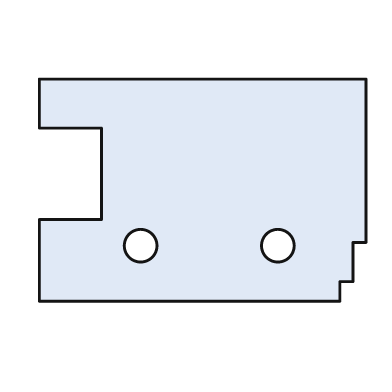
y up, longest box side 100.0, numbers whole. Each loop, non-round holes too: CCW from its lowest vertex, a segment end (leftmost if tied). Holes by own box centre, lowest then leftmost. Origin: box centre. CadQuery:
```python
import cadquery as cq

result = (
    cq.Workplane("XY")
    .moveTo(-50.0, -34.0)
    .lineTo(42.0, -34.0)
    .lineTo(42.0, -28.0)
    .lineTo(46.0, -28.0)
    .lineTo(46.0, -16.0)
    .lineTo(50.0, -16.0)
    .lineTo(50.0, 34.0)
    .lineTo(-50.0, 34.0)
    .lineTo(-50.0, 19.0)
    .lineTo(-31.0, 19.0)
    .lineTo(-31.0, -9.0)
    .lineTo(-50.0, -9.0)
    .close()
    .moveTo(-19.0, -17.0)
    .circle(5.0)
    .moveTo(23.0, -17.0)
    .circle(5.0)
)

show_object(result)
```